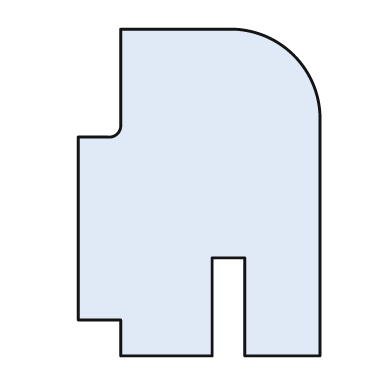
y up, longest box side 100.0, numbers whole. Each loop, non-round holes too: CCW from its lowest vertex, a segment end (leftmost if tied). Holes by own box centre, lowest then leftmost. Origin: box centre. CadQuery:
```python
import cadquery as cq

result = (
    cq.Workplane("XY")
    .moveTo(-24.0, -50.0)
    .lineTo(4.0, -50.0)
    .lineTo(4.0, -20.0)
    .lineTo(14.0, -20.0)
    .lineTo(14.0, -50.0)
    .lineTo(37.0, -50.0)
    .lineTo(37.0, 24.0)
    .threePointArc((29.0, 42.0), (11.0, 50.0))
    .lineTo(-24.0, 50.0)
    .lineTo(-24.0, 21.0)
    .threePointArc((-25.0, 18.0), (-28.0, 17.0))
    .lineTo(-37.0, 17.0)
    .lineTo(-37.0, -39.0)
    .lineTo(-24.0, -39.0)
    .close()
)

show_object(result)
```